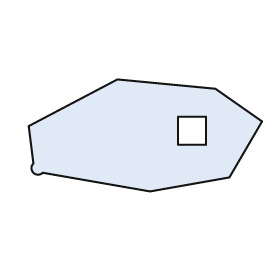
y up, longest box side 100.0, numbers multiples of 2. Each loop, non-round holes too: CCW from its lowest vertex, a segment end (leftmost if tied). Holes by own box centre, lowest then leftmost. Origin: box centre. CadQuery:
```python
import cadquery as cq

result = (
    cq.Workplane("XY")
    .moveTo(2.0, -24.0)
    .lineTo(36.0, -18.0)
    .lineTo(50.0, 6.0)
    .lineTo(30.0, 20.0)
    .lineTo(-12.0, 24.0)
    .lineTo(-50.0, 4.0)
    .lineTo(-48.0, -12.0)
    .threePointArc((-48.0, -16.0), (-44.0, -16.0))
    .close()
    .moveTo(14.0, -4.0)
    .lineTo(26.0, -4.0)
    .lineTo(26.0, 8.0)
    .lineTo(14.0, 8.0)
    .close()
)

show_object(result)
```